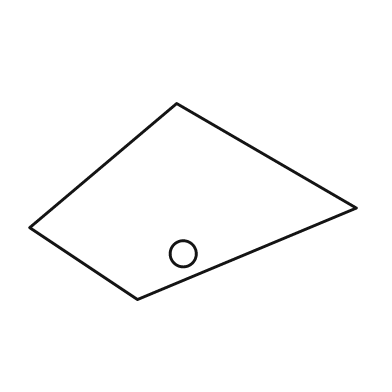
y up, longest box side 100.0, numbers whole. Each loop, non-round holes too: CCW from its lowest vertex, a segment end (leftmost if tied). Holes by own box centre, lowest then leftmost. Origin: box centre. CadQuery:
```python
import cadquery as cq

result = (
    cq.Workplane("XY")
    .moveTo(-17.0, -30.0)
    .lineTo(50.0, -2.0)
    .lineTo(-5.0, 30.0)
    .lineTo(-50.0, -8.0)
    .close()
    .moveTo(-3.0, -16.0)
    .circle(4.0)
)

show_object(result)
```